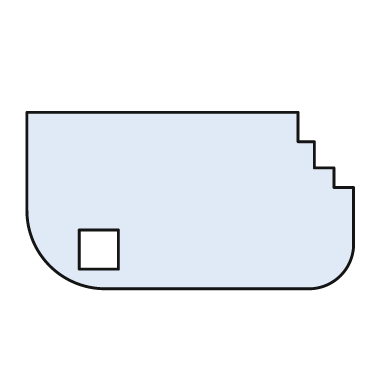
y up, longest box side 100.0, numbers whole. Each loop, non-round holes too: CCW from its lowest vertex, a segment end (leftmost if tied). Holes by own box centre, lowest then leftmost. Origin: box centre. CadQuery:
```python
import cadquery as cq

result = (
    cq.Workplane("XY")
    .moveTo(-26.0, -27.0)
    .lineTo(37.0, -27.0)
    .threePointArc((46.0, -23.0), (50.0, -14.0))
    .lineTo(50.0, 4.0)
    .lineTo(44.0, 4.0)
    .lineTo(44.0, 10.0)
    .lineTo(38.0, 10.0)
    .lineTo(38.0, 18.0)
    .lineTo(33.0, 18.0)
    .lineTo(33.0, 27.0)
    .lineTo(-50.0, 27.0)
    .lineTo(-50.0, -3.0)
    .threePointArc((-43.0, -20.0), (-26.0, -27.0))
    .close()
    .moveTo(-34.0, -21.0)
    .lineTo(-22.0, -21.0)
    .lineTo(-22.0, -9.0)
    .lineTo(-34.0, -9.0)
    .close()
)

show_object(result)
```